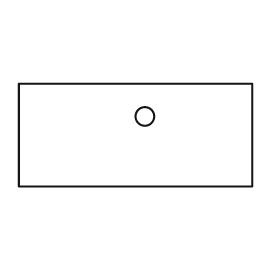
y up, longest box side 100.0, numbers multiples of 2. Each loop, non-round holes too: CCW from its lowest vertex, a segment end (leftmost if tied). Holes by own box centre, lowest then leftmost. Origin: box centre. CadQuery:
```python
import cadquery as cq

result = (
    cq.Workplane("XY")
    .moveTo(-50.0, -22.0)
    .lineTo(50.0, -22.0)
    .lineTo(50.0, 22.0)
    .lineTo(-50.0, 22.0)
    .close()
    .moveTo(4.0, 8.0)
    .circle(4.0)
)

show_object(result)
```